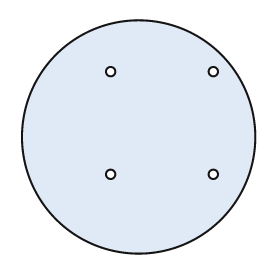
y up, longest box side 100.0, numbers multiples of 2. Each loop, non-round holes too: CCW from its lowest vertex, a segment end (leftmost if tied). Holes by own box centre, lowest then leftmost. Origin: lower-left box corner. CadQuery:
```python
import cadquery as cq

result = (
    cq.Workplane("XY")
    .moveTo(50.0, 50.0)
    .circle(50.0)
    .moveTo(38.0, 34.0)
    .circle(2.0)
    .moveTo(82.0, 34.0)
    .circle(2.0)
    .moveTo(38.0, 78.0)
    .circle(2.0)
    .moveTo(82.0, 78.0)
    .circle(2.0)
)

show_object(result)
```